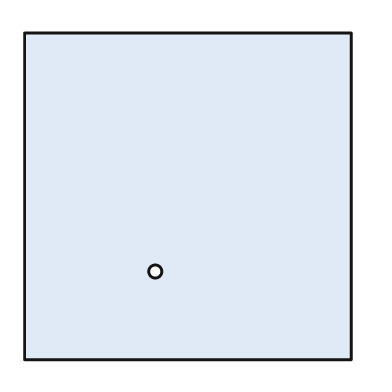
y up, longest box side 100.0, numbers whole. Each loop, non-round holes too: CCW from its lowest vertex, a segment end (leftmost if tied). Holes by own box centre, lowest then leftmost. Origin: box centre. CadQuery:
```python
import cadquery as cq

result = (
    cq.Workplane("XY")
    .moveTo(-50.0, -50.0)
    .lineTo(50.0, -50.0)
    .lineTo(50.0, 50.0)
    .lineTo(-50.0, 50.0)
    .close()
    .moveTo(-10.0, -23.0)
    .circle(2.0)
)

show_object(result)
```